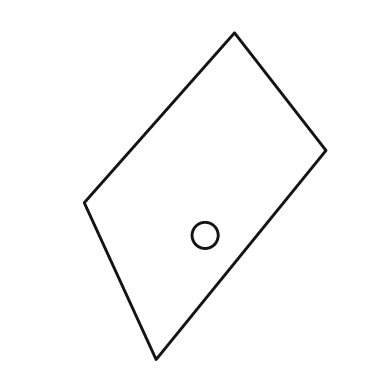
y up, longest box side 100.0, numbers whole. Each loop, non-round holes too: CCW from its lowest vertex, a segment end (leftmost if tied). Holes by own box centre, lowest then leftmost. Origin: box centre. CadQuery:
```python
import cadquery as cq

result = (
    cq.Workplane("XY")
    .moveTo(-15.0, -50.0)
    .lineTo(37.0, 14.0)
    .lineTo(9.0, 50.0)
    .lineTo(-37.0, -2.0)
    .close()
    .moveTo(0.0, -12.0)
    .circle(4.0)
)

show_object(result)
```